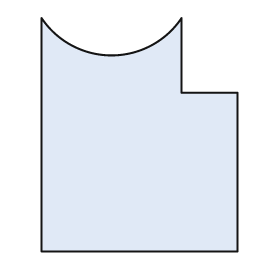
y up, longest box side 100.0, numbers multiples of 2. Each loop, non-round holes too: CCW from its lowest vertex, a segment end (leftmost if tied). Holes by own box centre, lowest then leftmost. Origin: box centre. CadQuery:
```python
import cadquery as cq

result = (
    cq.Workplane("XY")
    .moveTo(-42.0, -50.0)
    .lineTo(42.0, -50.0)
    .lineTo(42.0, 18.0)
    .lineTo(18.0, 18.0)
    .lineTo(18.0, 50.0)
    .threePointArc((-12.0, 34.0), (-42.0, 50.0))
    .close()
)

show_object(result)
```